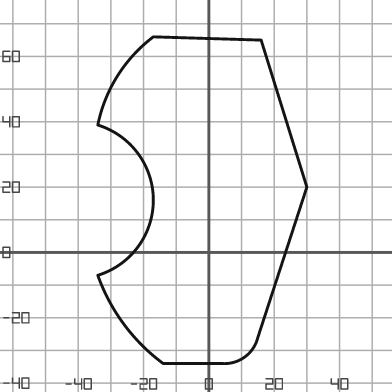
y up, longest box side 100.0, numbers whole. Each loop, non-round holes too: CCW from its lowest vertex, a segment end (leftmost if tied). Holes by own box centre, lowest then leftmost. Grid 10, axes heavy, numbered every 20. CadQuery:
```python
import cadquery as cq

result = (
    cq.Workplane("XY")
    .moveTo(-14.0, -34.0)
    .lineTo(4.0, -34.0)
    .threePointArc((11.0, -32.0), (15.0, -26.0))
    .lineTo(30.0, 20.0)
    .lineTo(16.0, 65.0)
    .lineTo(-17.0, 66.0)
    .threePointArc((-28.0, 54.0), (-34.0, 39.0))
    .threePointArc((-17.0, 16.0), (-34.0, -7.0))
    .threePointArc((-26.0, -22.0), (-14.0, -34.0))
    .close()
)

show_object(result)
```